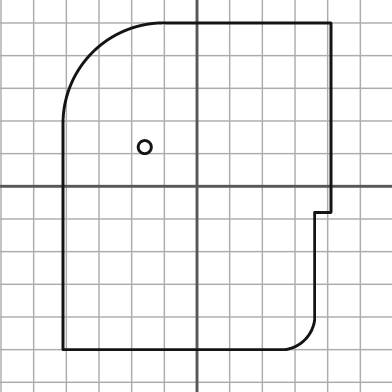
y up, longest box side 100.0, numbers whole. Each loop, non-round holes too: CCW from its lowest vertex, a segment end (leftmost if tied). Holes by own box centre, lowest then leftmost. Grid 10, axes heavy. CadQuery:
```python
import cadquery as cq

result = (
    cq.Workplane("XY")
    .moveTo(-41.0, -50.0)
    .lineTo(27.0, -50.0)
    .threePointArc((33.0, -47.0), (36.0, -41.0))
    .lineTo(36.0, -8.0)
    .lineTo(41.0, -8.0)
    .lineTo(41.0, 50.0)
    .lineTo(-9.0, 50.0)
    .threePointArc((-32.0, 41.0), (-41.0, 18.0))
    .close()
    .moveTo(-16.0, 12.0)
    .circle(2.0)
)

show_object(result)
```